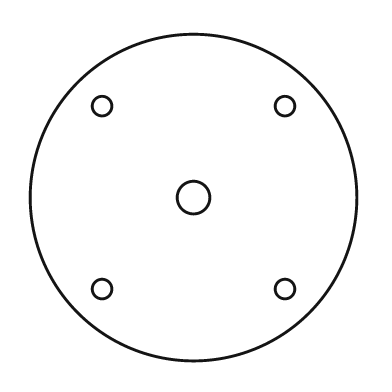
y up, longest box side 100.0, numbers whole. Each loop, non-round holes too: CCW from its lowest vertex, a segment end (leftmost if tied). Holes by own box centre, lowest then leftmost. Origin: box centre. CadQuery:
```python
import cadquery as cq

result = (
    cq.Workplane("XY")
    .moveTo(0.0, 0.0)
    .circle(50.0)
    .moveTo(-28.0, -28.0)
    .circle(3.0)
    .moveTo(28.0, -28.0)
    .circle(3.0)
    .moveTo(0.0, 0.0)
    .circle(5.0)
    .moveTo(-28.0, 28.0)
    .circle(3.0)
    .moveTo(28.0, 28.0)
    .circle(3.0)
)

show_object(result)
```